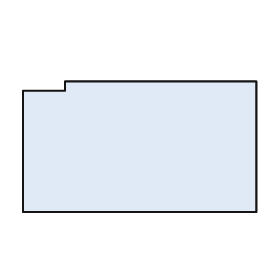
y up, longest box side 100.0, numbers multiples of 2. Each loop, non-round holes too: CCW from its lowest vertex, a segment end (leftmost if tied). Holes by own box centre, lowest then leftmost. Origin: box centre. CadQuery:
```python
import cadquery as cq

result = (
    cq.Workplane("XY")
    .moveTo(-50.0, -28.0)
    .lineTo(50.0, -28.0)
    .lineTo(50.0, 28.0)
    .lineTo(-32.0, 28.0)
    .lineTo(-32.0, 24.0)
    .lineTo(-50.0, 24.0)
    .close()
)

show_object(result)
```